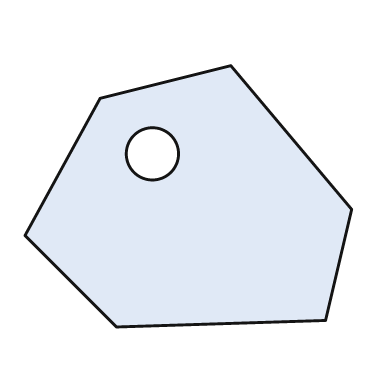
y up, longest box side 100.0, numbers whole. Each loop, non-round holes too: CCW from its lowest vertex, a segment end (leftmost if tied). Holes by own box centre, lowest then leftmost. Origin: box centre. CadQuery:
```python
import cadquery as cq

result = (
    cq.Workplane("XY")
    .moveTo(-22.0, -40.0)
    .lineTo(42.0, -38.0)
    .lineTo(50.0, -4.0)
    .lineTo(13.0, 40.0)
    .lineTo(-27.0, 30.0)
    .lineTo(-50.0, -12.0)
    .close()
    .moveTo(-11.0, 13.0)
    .circle(8.0)
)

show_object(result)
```